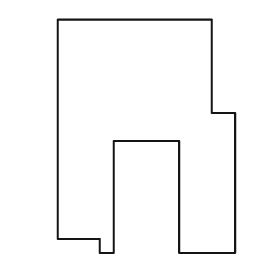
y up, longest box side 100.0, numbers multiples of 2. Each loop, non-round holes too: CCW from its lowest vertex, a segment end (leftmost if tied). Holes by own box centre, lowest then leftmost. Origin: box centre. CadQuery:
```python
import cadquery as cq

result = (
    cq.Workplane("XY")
    .moveTo(-20.0, -50.0)
    .lineTo(-14.0, -50.0)
    .lineTo(-14.0, -2.0)
    .lineTo(14.0, -2.0)
    .lineTo(14.0, -50.0)
    .lineTo(38.0, -50.0)
    .lineTo(38.0, 10.0)
    .lineTo(28.0, 10.0)
    .lineTo(28.0, 50.0)
    .lineTo(-38.0, 50.0)
    .lineTo(-38.0, -44.0)
    .lineTo(-20.0, -44.0)
    .close()
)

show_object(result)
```